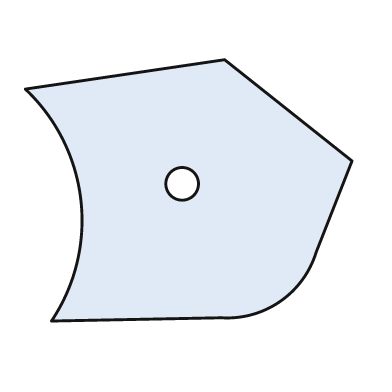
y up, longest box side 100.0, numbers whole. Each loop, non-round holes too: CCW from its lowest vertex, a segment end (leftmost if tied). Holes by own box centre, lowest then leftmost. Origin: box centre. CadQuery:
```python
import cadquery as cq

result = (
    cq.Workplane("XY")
    .moveTo(-42.0, -40.0)
    .lineTo(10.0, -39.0)
    .threePointArc((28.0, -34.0), (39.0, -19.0))
    .lineTo(50.0, 9.0)
    .lineTo(11.0, 40.0)
    .lineTo(-50.0, 31.0)
    .threePointArc((-33.0, -3.0), (-42.0, -40.0))
    .close()
    .moveTo(-2.0, 2.0)
    .circle(5.0)
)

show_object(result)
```